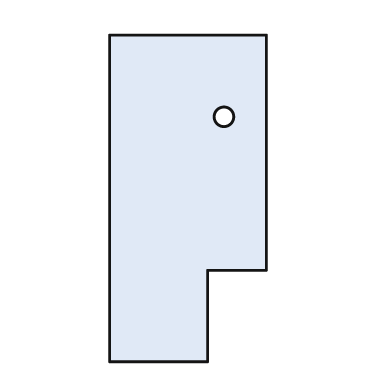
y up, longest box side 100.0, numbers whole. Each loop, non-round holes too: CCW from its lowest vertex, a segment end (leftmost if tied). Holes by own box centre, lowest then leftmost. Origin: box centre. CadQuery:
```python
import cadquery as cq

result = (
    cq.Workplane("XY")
    .moveTo(-24.0, -50.0)
    .lineTo(6.0, -50.0)
    .lineTo(6.0, -22.0)
    .lineTo(24.0, -22.0)
    .lineTo(24.0, 50.0)
    .lineTo(-24.0, 50.0)
    .close()
    .moveTo(11.0, 25.0)
    .circle(3.0)
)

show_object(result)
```